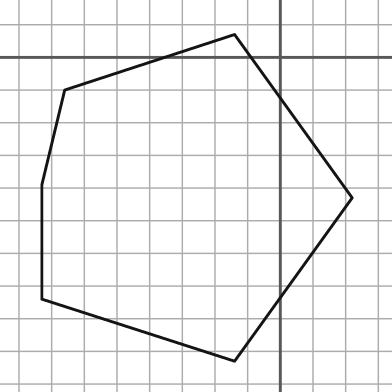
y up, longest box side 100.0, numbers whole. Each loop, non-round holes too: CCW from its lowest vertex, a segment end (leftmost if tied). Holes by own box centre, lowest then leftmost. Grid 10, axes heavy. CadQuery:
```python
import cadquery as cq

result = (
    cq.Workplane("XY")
    .moveTo(-14.0, -93.0)
    .lineTo(22.0, -43.0)
    .lineTo(-14.0, 7.0)
    .lineTo(-66.0, -10.0)
    .lineTo(-73.0, -39.0)
    .lineTo(-73.0, -74.0)
    .close()
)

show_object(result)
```